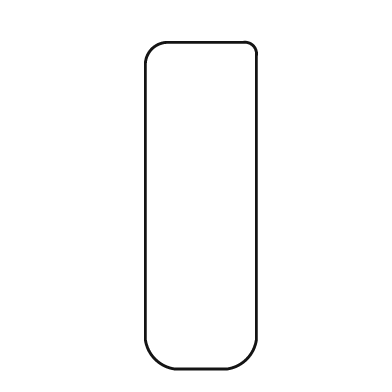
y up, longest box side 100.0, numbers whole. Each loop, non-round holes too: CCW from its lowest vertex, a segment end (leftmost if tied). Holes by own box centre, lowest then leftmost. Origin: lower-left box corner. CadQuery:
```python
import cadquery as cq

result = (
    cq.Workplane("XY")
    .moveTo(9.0, 0.0)
    .lineTo(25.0, 0.0)
    .threePointArc((31.0, 3.0), (34.0, 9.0))
    .lineTo(34.0, 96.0)
    .threePointArc((33.0, 99.0), (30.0, 100.0))
    .lineTo(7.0, 100.0)
    .threePointArc((2.0, 98.0), (0.0, 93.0))
    .lineTo(0.0, 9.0)
    .threePointArc((3.0, 3.0), (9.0, 0.0))
    .close()
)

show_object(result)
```